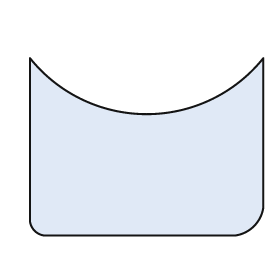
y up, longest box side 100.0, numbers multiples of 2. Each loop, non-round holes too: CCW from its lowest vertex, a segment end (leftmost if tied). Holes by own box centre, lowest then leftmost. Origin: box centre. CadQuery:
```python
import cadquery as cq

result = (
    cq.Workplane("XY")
    .moveTo(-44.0, -38.0)
    .lineTo(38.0, -38.0)
    .threePointArc((46.0, -34.0), (50.0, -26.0))
    .lineTo(50.0, 38.0)
    .threePointArc((0.0, 14.0), (-50.0, 38.0))
    .lineTo(-50.0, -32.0)
    .threePointArc((-48.0, -36.0), (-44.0, -38.0))
    .close()
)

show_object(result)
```